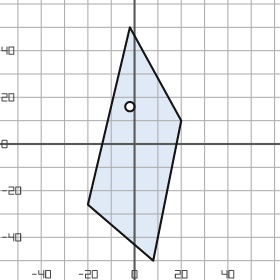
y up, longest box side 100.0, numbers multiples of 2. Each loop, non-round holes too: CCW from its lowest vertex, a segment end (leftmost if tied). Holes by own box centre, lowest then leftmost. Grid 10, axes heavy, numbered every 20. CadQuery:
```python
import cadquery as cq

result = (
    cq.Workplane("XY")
    .moveTo(8.0, -50.0)
    .lineTo(20.0, 10.0)
    .lineTo(-2.0, 50.0)
    .lineTo(-20.0, -26.0)
    .close()
    .moveTo(-2.0, 16.0)
    .circle(2.0)
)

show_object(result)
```